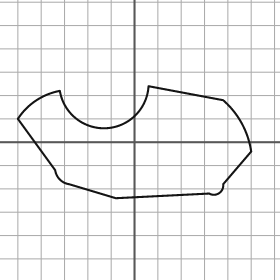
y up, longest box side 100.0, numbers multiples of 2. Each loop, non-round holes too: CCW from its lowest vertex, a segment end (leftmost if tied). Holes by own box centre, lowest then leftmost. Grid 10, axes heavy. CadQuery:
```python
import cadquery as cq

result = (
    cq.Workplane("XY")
    .moveTo(-8.0, -24.0)
    .lineTo(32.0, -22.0)
    .threePointArc((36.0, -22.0), (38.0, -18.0))
    .lineTo(50.0, -4.0)
    .threePointArc((46.0, 8.0), (38.0, 18.0))
    .lineTo(6.0, 24.0)
    .threePointArc((-12.0, 6.0), (-32.0, 22.0))
    .threePointArc((-42.0, 18.0), (-50.0, 10.0))
    .lineTo(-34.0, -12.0)
    .threePointArc((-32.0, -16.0), (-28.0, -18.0))
    .close()
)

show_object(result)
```